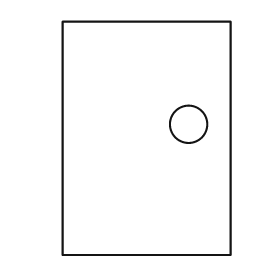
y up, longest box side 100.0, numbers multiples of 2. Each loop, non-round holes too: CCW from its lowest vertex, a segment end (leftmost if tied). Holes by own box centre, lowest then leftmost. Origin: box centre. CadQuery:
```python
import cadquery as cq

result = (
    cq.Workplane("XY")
    .moveTo(-36.0, -50.0)
    .lineTo(36.0, -50.0)
    .lineTo(36.0, 50.0)
    .lineTo(-36.0, 50.0)
    .close()
    .moveTo(18.0, 6.0)
    .circle(8.0)
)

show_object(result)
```